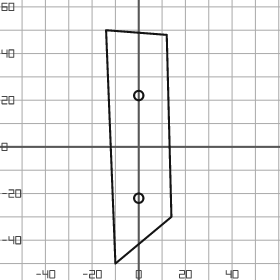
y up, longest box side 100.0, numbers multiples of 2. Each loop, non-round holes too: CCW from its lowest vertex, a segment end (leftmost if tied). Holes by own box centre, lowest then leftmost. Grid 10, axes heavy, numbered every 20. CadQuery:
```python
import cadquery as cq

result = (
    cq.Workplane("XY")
    .moveTo(-10.0, -50.0)
    .lineTo(14.0, -30.0)
    .lineTo(12.0, 48.0)
    .lineTo(-14.0, 50.0)
    .close()
    .moveTo(0.0, -22.0)
    .circle(2.0)
    .moveTo(0.0, 22.0)
    .circle(2.0)
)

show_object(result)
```